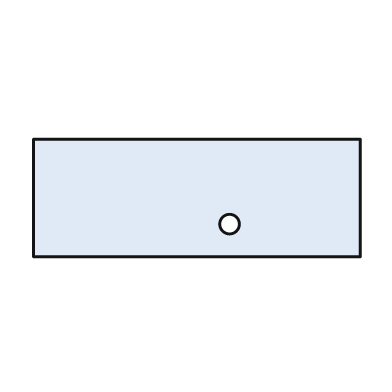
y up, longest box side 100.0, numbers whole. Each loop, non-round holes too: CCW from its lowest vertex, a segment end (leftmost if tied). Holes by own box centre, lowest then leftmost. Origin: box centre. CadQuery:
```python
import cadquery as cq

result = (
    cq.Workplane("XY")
    .moveTo(-50.0, -18.0)
    .lineTo(50.0, -18.0)
    .lineTo(50.0, 18.0)
    .lineTo(-50.0, 18.0)
    .close()
    .moveTo(10.0, -8.0)
    .circle(3.0)
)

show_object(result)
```